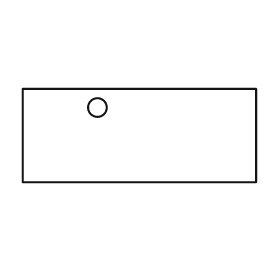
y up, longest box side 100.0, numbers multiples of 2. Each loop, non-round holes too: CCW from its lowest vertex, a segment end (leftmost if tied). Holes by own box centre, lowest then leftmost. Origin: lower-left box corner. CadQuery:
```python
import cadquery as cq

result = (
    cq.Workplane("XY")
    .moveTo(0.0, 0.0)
    .lineTo(100.0, 0.0)
    .lineTo(100.0, 40.0)
    .lineTo(0.0, 40.0)
    .close()
    .moveTo(32.0, 32.0)
    .circle(4.0)
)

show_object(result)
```